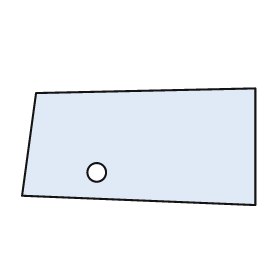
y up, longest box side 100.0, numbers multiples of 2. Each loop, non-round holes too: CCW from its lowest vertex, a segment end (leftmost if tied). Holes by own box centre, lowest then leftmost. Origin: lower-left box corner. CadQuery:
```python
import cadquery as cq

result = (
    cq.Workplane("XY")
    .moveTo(100.0, 0.0)
    .lineTo(100.0, 50.0)
    .lineTo(6.0, 48.0)
    .lineTo(0.0, 4.0)
    .close()
    .moveTo(32.0, 14.0)
    .circle(4.0)
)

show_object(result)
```